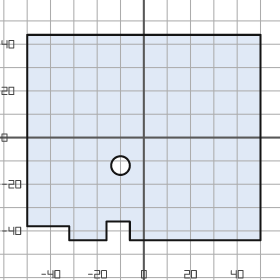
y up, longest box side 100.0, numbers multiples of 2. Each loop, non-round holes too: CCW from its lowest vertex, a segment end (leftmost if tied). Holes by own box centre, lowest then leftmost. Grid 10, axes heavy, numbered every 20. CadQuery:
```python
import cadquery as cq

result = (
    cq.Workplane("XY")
    .moveTo(-32.0, -44.0)
    .lineTo(-16.0, -44.0)
    .lineTo(-16.0, -36.0)
    .lineTo(-6.0, -36.0)
    .lineTo(-6.0, -44.0)
    .lineTo(50.0, -44.0)
    .lineTo(50.0, 44.0)
    .lineTo(-50.0, 44.0)
    .lineTo(-50.0, -38.0)
    .lineTo(-32.0, -38.0)
    .close()
    .moveTo(-10.0, -12.0)
    .circle(4.0)
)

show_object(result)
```